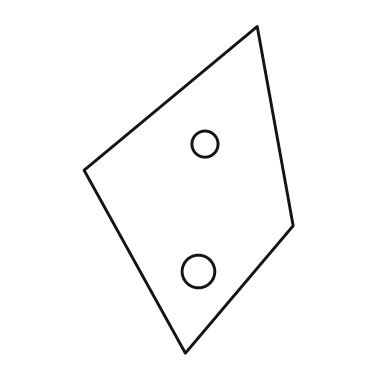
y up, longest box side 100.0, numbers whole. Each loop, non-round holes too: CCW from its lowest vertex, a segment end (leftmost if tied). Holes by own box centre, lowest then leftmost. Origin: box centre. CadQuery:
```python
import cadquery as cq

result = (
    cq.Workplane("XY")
    .moveTo(-1.0, -50.0)
    .lineTo(32.0, -11.0)
    .lineTo(21.0, 50.0)
    .lineTo(-32.0, 6.0)
    .close()
    .moveTo(3.0, -25.0)
    .circle(5.0)
    .moveTo(5.0, 14.0)
    .circle(4.0)
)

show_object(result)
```